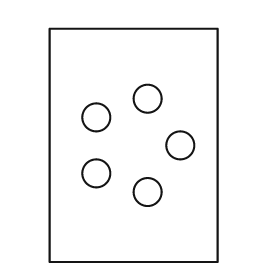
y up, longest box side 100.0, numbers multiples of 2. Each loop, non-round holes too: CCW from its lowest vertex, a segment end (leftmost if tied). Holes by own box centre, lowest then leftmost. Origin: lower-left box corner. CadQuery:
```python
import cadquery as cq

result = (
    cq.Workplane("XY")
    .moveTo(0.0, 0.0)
    .lineTo(72.0, 0.0)
    .lineTo(72.0, 100.0)
    .lineTo(0.0, 100.0)
    .close()
    .moveTo(42.0, 30.0)
    .circle(6.0)
    .moveTo(20.0, 38.0)
    .circle(6.0)
    .moveTo(56.0, 50.0)
    .circle(6.0)
    .moveTo(20.0, 62.0)
    .circle(6.0)
    .moveTo(42.0, 70.0)
    .circle(6.0)
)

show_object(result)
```